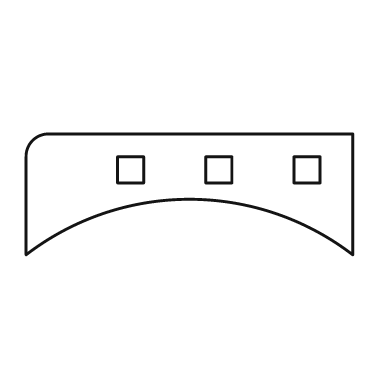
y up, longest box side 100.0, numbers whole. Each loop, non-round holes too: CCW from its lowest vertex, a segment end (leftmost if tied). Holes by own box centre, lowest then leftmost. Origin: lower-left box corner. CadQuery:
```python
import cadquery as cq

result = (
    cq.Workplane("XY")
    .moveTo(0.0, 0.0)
    .threePointArc((50.0, 17.0), (100.0, 0.0))
    .lineTo(100.0, 37.0)
    .lineTo(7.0, 37.0)
    .threePointArc((2.0, 35.0), (0.0, 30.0))
    .close()
    .moveTo(28.0, 22.0)
    .lineTo(36.0, 22.0)
    .lineTo(36.0, 30.0)
    .lineTo(28.0, 30.0)
    .close()
    .moveTo(55.0, 22.0)
    .lineTo(63.0, 22.0)
    .lineTo(63.0, 30.0)
    .lineTo(55.0, 30.0)
    .close()
    .moveTo(82.0, 22.0)
    .lineTo(90.0, 22.0)
    .lineTo(90.0, 30.0)
    .lineTo(82.0, 30.0)
    .close()
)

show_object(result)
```